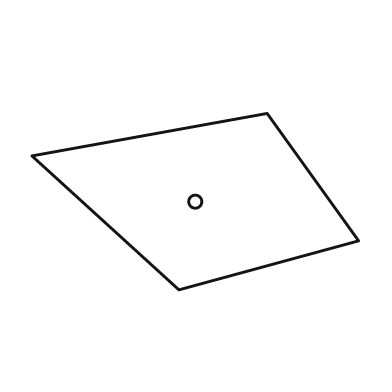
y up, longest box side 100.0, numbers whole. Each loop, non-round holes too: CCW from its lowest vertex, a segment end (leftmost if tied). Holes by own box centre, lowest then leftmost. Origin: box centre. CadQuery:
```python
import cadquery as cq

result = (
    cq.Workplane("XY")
    .moveTo(-5.0, -27.0)
    .lineTo(50.0, -12.0)
    .lineTo(22.0, 27.0)
    .lineTo(-50.0, 14.0)
    .close()
    .moveTo(0.0, 0.0)
    .circle(2.0)
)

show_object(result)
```